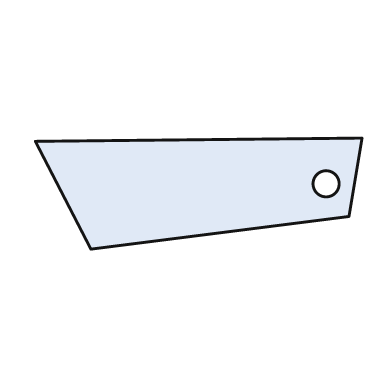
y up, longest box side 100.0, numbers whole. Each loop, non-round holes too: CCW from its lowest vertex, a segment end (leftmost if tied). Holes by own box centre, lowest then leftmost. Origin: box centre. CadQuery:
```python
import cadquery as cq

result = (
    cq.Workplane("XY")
    .moveTo(-33.0, -17.0)
    .lineTo(46.0, -7.0)
    .lineTo(50.0, 17.0)
    .lineTo(-50.0, 16.0)
    .close()
    .moveTo(39.0, 3.0)
    .circle(4.0)
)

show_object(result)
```